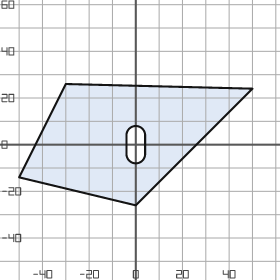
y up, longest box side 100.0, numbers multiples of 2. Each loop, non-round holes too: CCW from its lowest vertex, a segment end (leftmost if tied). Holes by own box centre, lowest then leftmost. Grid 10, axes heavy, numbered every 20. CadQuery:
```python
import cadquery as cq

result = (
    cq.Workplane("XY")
    .moveTo(0.0, -26.0)
    .lineTo(50.0, 24.0)
    .lineTo(-30.0, 26.0)
    .lineTo(-50.0, -14.0)
    .close()
    .moveTo(-4.0, -4.0)
    .threePointArc((0.0, -8.0), (4.0, -4.0))
    .lineTo(4.0, 4.0)
    .threePointArc((0.0, 8.0), (-4.0, 4.0))
    .close()
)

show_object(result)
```